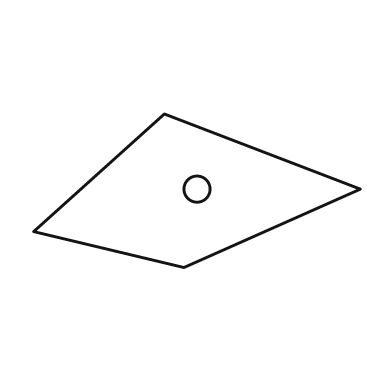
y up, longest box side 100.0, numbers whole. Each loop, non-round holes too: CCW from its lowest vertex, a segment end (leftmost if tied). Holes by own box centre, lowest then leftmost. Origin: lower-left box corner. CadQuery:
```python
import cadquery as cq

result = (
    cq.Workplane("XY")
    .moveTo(46.0, 0.0)
    .lineTo(100.0, 24.0)
    .lineTo(40.0, 47.0)
    .lineTo(0.0, 11.0)
    .close()
    .moveTo(50.0, 24.0)
    .circle(4.0)
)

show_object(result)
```